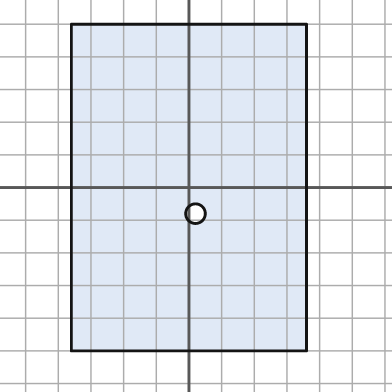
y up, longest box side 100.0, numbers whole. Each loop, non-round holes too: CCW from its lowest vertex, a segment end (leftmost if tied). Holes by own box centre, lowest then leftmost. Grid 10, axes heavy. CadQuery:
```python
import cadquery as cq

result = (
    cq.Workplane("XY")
    .moveTo(-36.0, -50.0)
    .lineTo(36.0, -50.0)
    .lineTo(36.0, 50.0)
    .lineTo(-36.0, 50.0)
    .close()
    .moveTo(2.0, -8.0)
    .circle(3.0)
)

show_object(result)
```